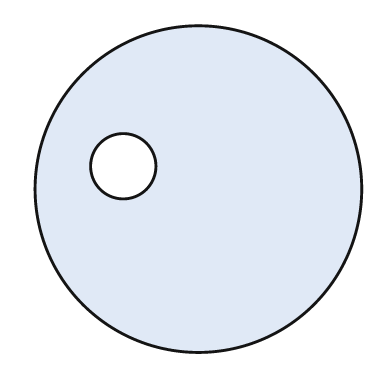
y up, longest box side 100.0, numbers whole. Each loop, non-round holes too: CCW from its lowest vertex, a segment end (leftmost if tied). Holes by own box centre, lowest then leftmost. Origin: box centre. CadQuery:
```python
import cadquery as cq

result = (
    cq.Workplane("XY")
    .moveTo(0.0, 0.0)
    .circle(50.0)
    .moveTo(-23.0, 7.0)
    .circle(10.0)
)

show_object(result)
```